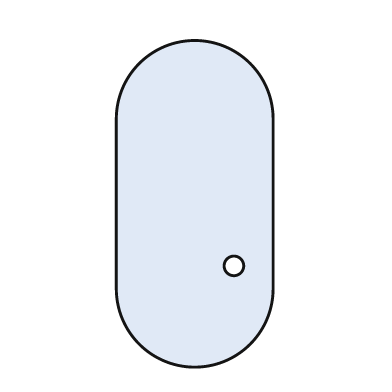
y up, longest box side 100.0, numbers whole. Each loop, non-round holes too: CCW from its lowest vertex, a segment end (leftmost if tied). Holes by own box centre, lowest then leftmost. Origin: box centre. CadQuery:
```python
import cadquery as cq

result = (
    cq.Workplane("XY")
    .moveTo(-24.0, -26.0)
    .threePointArc((0.0, -50.0), (24.0, -26.0))
    .lineTo(24.0, 26.0)
    .threePointArc((0.0, 50.0), (-24.0, 26.0))
    .close()
    .moveTo(12.0, -19.0)
    .circle(3.0)
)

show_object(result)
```